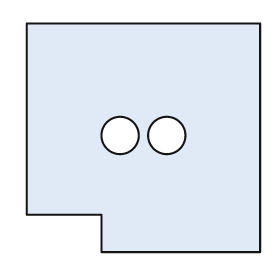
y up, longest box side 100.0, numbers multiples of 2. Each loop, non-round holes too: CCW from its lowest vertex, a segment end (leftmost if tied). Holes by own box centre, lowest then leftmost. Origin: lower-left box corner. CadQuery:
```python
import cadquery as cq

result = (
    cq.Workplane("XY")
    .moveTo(32.0, 0.0)
    .lineTo(100.0, 0.0)
    .lineTo(100.0, 98.0)
    .lineTo(0.0, 98.0)
    .lineTo(0.0, 16.0)
    .lineTo(32.0, 16.0)
    .close()
    .moveTo(40.0, 50.0)
    .circle(8.0)
    .moveTo(60.0, 50.0)
    .circle(8.0)
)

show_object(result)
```